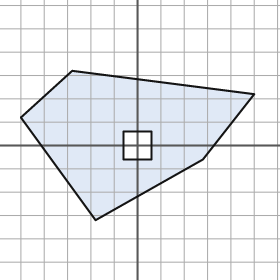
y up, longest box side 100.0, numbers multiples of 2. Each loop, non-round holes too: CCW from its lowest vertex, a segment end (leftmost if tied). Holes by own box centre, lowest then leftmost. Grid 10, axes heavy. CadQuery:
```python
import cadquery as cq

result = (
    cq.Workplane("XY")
    .moveTo(-18.0, -32.0)
    .lineTo(28.0, -6.0)
    .lineTo(50.0, 22.0)
    .lineTo(-28.0, 32.0)
    .lineTo(-50.0, 12.0)
    .close()
    .moveTo(-6.0, -6.0)
    .lineTo(6.0, -6.0)
    .lineTo(6.0, 6.0)
    .lineTo(-6.0, 6.0)
    .close()
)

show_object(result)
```